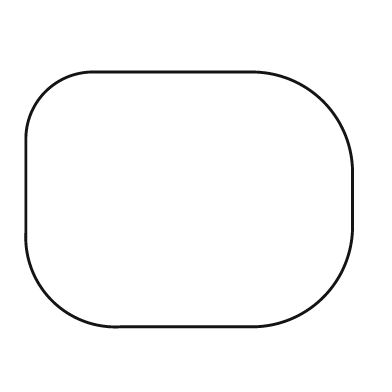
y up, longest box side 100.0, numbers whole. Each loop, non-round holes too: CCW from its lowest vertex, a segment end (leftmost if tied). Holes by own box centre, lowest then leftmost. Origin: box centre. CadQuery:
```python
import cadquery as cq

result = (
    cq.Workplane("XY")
    .moveTo(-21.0, -39.0)
    .lineTo(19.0, -39.0)
    .threePointArc((41.0, -30.0), (50.0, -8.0))
    .lineTo(50.0, 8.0)
    .threePointArc((41.0, 30.0), (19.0, 39.0))
    .lineTo(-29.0, 39.0)
    .threePointArc((-44.0, 33.0), (-50.0, 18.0))
    .lineTo(-50.0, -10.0)
    .threePointArc((-42.0, -31.0), (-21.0, -39.0))
    .close()
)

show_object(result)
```